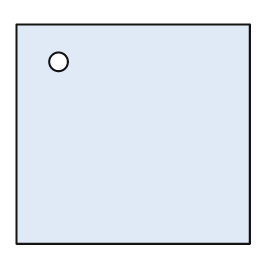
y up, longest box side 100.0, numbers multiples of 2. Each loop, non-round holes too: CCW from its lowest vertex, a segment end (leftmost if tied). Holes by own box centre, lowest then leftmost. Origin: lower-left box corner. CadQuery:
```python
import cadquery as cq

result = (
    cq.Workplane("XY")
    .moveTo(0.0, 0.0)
    .lineTo(100.0, 0.0)
    .lineTo(100.0, 94.0)
    .lineTo(0.0, 94.0)
    .close()
    .moveTo(18.0, 78.0)
    .circle(4.0)
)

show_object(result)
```